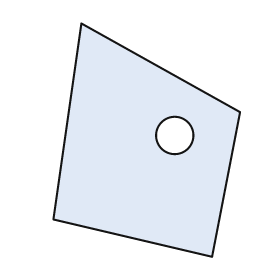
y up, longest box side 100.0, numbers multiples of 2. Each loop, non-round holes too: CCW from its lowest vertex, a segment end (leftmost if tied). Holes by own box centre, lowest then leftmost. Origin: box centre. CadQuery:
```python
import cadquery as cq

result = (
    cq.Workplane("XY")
    .moveTo(28.0, -50.0)
    .lineTo(40.0, 12.0)
    .lineTo(-28.0, 50.0)
    .lineTo(-40.0, -34.0)
    .close()
    .moveTo(12.0, 2.0)
    .circle(8.0)
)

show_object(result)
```